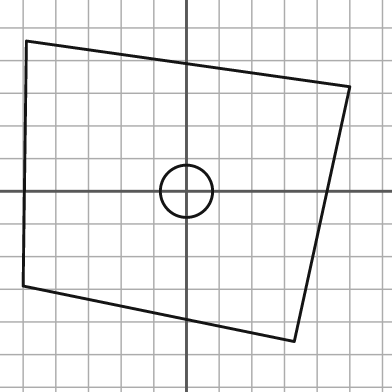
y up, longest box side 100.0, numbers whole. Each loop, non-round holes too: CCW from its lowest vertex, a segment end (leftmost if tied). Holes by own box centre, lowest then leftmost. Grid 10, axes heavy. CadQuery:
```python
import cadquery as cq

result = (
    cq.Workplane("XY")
    .moveTo(33.0, -46.0)
    .lineTo(50.0, 32.0)
    .lineTo(-49.0, 46.0)
    .lineTo(-50.0, -29.0)
    .close()
    .moveTo(0.0, 0.0)
    .circle(8.0)
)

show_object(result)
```